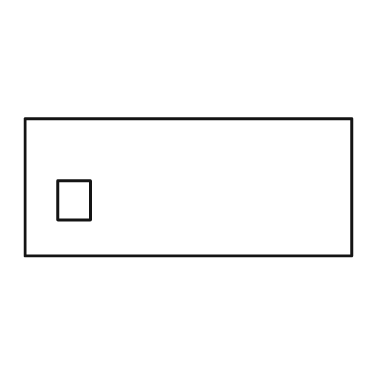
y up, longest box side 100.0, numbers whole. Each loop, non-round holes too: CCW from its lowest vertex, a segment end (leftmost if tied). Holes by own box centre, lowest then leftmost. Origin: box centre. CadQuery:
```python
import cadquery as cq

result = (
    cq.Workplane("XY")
    .moveTo(-50.0, -21.0)
    .lineTo(50.0, -21.0)
    .lineTo(50.0, 21.0)
    .lineTo(-50.0, 21.0)
    .close()
    .moveTo(-40.0, -10.0)
    .lineTo(-30.0, -10.0)
    .lineTo(-30.0, 2.0)
    .lineTo(-40.0, 2.0)
    .close()
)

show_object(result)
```